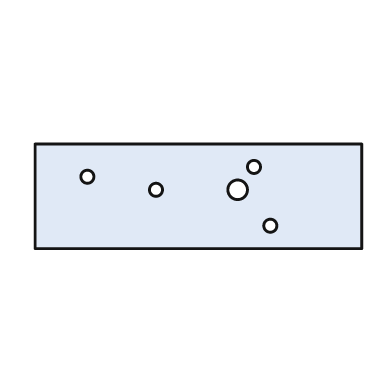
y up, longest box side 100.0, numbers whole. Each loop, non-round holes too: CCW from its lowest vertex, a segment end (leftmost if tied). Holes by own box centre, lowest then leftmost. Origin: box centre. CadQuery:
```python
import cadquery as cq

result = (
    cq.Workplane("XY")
    .moveTo(-50.0, -16.0)
    .lineTo(50.0, -16.0)
    .lineTo(50.0, 16.0)
    .lineTo(-50.0, 16.0)
    .close()
    .moveTo(22.0, -9.0)
    .circle(2.0)
    .moveTo(-13.0, 2.0)
    .circle(2.0)
    .moveTo(12.0, 2.0)
    .circle(3.0)
    .moveTo(-34.0, 6.0)
    .circle(2.0)
    .moveTo(17.0, 9.0)
    .circle(2.0)
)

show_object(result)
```